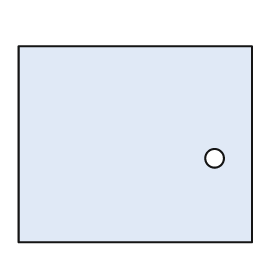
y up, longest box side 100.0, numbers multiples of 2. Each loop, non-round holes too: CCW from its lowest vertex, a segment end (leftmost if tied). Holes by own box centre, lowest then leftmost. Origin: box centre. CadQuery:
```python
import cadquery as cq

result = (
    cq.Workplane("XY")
    .moveTo(-50.0, -42.0)
    .lineTo(50.0, -42.0)
    .lineTo(50.0, 42.0)
    .lineTo(-50.0, 42.0)
    .close()
    .moveTo(34.0, -6.0)
    .circle(4.0)
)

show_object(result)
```